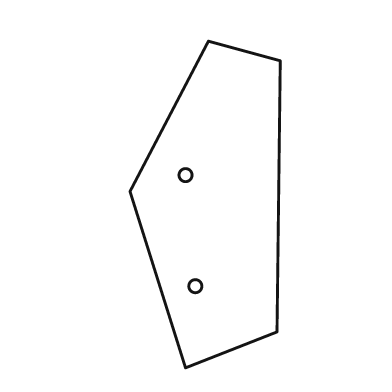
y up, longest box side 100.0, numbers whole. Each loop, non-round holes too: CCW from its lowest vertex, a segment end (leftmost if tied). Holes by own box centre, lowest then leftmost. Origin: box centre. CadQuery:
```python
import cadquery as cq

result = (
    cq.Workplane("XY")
    .moveTo(-6.0, -50.0)
    .lineTo(22.0, -39.0)
    .lineTo(23.0, 44.0)
    .lineTo(1.0, 50.0)
    .lineTo(-23.0, 4.0)
    .close()
    .moveTo(-3.0, -25.0)
    .circle(2.0)
    .moveTo(-6.0, 9.0)
    .circle(2.0)
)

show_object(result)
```